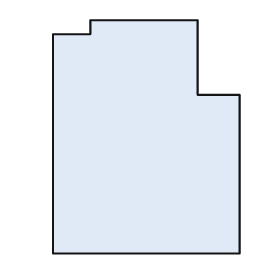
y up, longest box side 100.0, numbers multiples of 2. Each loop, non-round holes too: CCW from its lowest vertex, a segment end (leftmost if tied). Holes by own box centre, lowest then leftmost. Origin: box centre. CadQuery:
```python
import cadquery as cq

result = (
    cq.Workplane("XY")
    .moveTo(-40.0, -50.0)
    .lineTo(40.0, -50.0)
    .lineTo(40.0, 18.0)
    .lineTo(22.0, 18.0)
    .lineTo(22.0, 50.0)
    .lineTo(-24.0, 50.0)
    .lineTo(-24.0, 44.0)
    .lineTo(-40.0, 44.0)
    .close()
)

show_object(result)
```